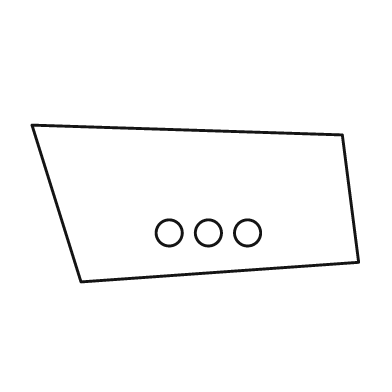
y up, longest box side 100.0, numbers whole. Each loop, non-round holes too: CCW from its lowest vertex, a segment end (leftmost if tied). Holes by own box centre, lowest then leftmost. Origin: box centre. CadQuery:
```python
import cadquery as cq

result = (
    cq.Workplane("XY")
    .moveTo(-35.0, -24.0)
    .lineTo(50.0, -18.0)
    .lineTo(45.0, 21.0)
    .lineTo(-50.0, 24.0)
    .close()
    .moveTo(-8.0, -9.0)
    .circle(4.0)
    .moveTo(4.0, -9.0)
    .circle(4.0)
    .moveTo(16.0, -9.0)
    .circle(4.0)
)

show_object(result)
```